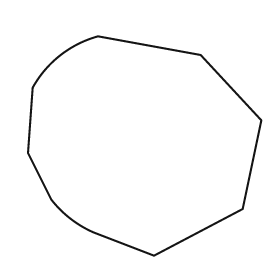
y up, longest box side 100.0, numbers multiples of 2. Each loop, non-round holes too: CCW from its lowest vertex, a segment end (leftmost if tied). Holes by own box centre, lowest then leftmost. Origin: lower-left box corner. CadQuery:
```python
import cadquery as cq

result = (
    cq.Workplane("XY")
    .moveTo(54.0, 0.0)
    .lineTo(92.0, 20.0)
    .lineTo(100.0, 58.0)
    .lineTo(74.0, 86.0)
    .lineTo(30.0, 94.0)
    .threePointArc((14.0, 86.0), (2.0, 72.0))
    .lineTo(0.0, 44.0)
    .lineTo(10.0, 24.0)
    .threePointArc((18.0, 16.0), (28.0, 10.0))
    .close()
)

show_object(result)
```